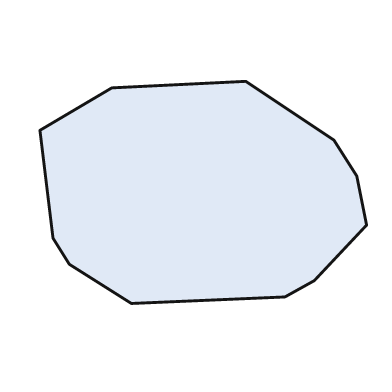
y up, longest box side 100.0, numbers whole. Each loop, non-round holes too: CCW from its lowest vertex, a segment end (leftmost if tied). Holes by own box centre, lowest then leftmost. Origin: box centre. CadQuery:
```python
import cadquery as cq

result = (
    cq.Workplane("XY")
    .moveTo(-22.0, -34.0)
    .lineTo(25.0, -32.0)
    .lineTo(34.0, -27.0)
    .lineTo(50.0, -10.0)
    .lineTo(47.0, 5.0)
    .lineTo(40.0, 16.0)
    .lineTo(13.0, 34.0)
    .lineTo(-28.0, 32.0)
    .lineTo(-50.0, 19.0)
    .lineTo(-46.0, -14.0)
    .lineTo(-41.0, -22.0)
    .close()
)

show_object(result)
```